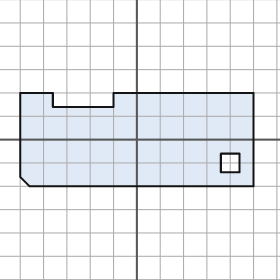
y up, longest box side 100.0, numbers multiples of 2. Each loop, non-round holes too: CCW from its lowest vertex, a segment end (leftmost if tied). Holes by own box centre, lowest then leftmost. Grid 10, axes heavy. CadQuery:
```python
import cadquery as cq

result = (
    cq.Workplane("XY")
    .moveTo(-46.0, -20.0)
    .lineTo(50.0, -20.0)
    .lineTo(50.0, 20.0)
    .lineTo(-10.0, 20.0)
    .lineTo(-10.0, 14.0)
    .lineTo(-36.0, 14.0)
    .lineTo(-36.0, 20.0)
    .lineTo(-50.0, 20.0)
    .lineTo(-50.0, -16.0)
    .close()
    .moveTo(36.0, -14.0)
    .lineTo(44.0, -14.0)
    .lineTo(44.0, -6.0)
    .lineTo(36.0, -6.0)
    .close()
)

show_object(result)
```